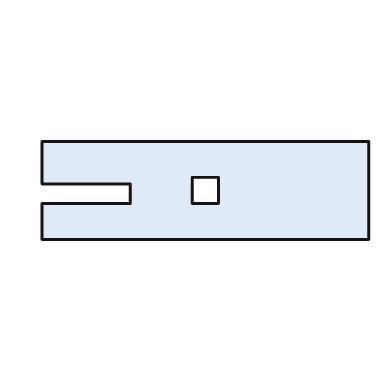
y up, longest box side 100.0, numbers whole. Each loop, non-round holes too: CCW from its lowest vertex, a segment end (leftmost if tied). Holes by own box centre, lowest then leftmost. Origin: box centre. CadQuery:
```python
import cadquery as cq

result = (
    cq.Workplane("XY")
    .moveTo(-50.0, -15.0)
    .lineTo(50.0, -15.0)
    .lineTo(50.0, 15.0)
    .lineTo(-50.0, 15.0)
    .lineTo(-50.0, 2.0)
    .lineTo(-23.0, 2.0)
    .lineTo(-23.0, -4.0)
    .lineTo(-50.0, -4.0)
    .close()
    .moveTo(-4.0, -4.0)
    .lineTo(4.0, -4.0)
    .lineTo(4.0, 4.0)
    .lineTo(-4.0, 4.0)
    .close()
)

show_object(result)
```